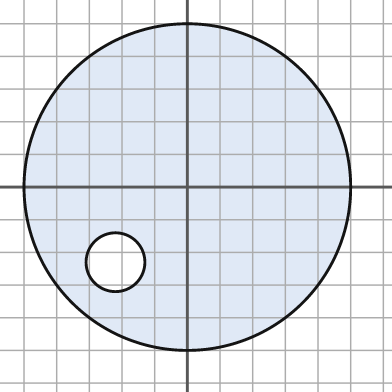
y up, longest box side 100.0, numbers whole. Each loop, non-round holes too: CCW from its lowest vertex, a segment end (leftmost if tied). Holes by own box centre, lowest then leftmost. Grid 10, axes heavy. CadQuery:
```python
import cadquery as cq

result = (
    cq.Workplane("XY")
    .moveTo(0.0, 0.0)
    .circle(50.0)
    .moveTo(-22.0, -23.0)
    .circle(9.0)
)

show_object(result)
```